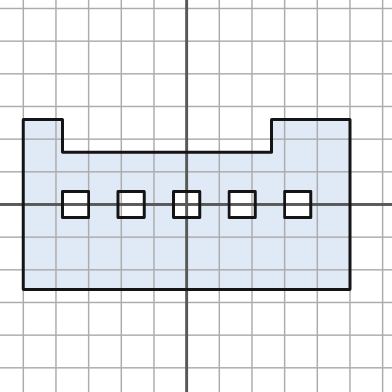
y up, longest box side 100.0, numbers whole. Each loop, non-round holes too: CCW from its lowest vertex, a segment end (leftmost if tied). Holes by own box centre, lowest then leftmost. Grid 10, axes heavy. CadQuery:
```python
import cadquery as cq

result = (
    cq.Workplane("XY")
    .moveTo(-50.0, -26.0)
    .lineTo(50.0, -26.0)
    .lineTo(50.0, 26.0)
    .lineTo(26.0, 26.0)
    .lineTo(26.0, 16.0)
    .lineTo(-38.0, 16.0)
    .lineTo(-38.0, 26.0)
    .lineTo(-50.0, 26.0)
    .close()
    .moveTo(-38.0, -4.0)
    .lineTo(-30.0, -4.0)
    .lineTo(-30.0, 4.0)
    .lineTo(-38.0, 4.0)
    .close()
    .moveTo(-21.0, -4.0)
    .lineTo(-13.0, -4.0)
    .lineTo(-13.0, 4.0)
    .lineTo(-21.0, 4.0)
    .close()
    .moveTo(-4.0, -4.0)
    .lineTo(4.0, -4.0)
    .lineTo(4.0, 4.0)
    .lineTo(-4.0, 4.0)
    .close()
    .moveTo(13.0, -4.0)
    .lineTo(21.0, -4.0)
    .lineTo(21.0, 4.0)
    .lineTo(13.0, 4.0)
    .close()
    .moveTo(30.0, -4.0)
    .lineTo(38.0, -4.0)
    .lineTo(38.0, 4.0)
    .lineTo(30.0, 4.0)
    .close()
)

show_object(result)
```